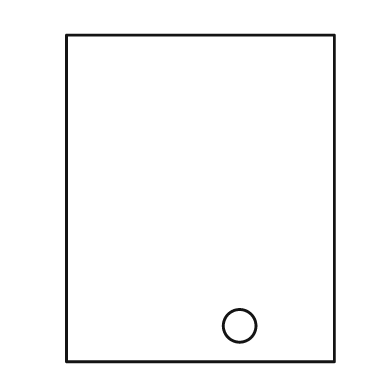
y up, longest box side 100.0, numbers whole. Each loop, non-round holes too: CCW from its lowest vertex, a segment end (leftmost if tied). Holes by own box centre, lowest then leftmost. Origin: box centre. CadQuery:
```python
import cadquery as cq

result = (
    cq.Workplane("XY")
    .moveTo(-41.0, -50.0)
    .lineTo(41.0, -50.0)
    .lineTo(41.0, 50.0)
    .lineTo(-41.0, 50.0)
    .close()
    .moveTo(12.0, -39.0)
    .circle(5.0)
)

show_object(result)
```